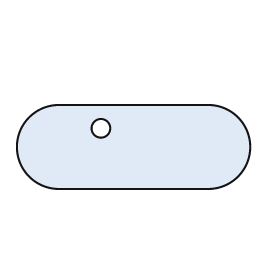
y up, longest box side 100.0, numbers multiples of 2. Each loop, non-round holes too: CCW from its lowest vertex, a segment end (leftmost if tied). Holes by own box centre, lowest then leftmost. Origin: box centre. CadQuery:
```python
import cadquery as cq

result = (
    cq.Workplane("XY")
    .moveTo(-32.0, -18.0)
    .lineTo(32.0, -18.0)
    .threePointArc((50.0, 0.0), (32.0, 18.0))
    .lineTo(-32.0, 18.0)
    .threePointArc((-50.0, 0.0), (-32.0, -18.0))
    .close()
    .moveTo(-14.0, 8.0)
    .circle(4.0)
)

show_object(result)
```